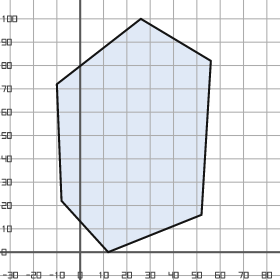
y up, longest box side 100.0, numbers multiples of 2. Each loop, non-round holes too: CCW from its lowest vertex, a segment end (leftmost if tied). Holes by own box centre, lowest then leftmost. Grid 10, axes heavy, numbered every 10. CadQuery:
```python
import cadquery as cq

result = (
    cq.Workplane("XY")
    .moveTo(12.0, 0.0)
    .lineTo(52.0, 16.0)
    .lineTo(56.0, 82.0)
    .lineTo(26.0, 100.0)
    .lineTo(-10.0, 72.0)
    .lineTo(-8.0, 22.0)
    .close()
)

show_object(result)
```